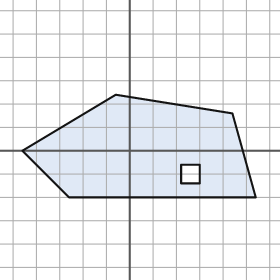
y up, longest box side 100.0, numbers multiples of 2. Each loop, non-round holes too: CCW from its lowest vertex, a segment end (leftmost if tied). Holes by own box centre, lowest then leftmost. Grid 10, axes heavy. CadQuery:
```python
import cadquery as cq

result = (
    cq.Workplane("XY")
    .moveTo(-26.0, -20.0)
    .lineTo(54.0, -20.0)
    .lineTo(44.0, 16.0)
    .lineTo(-6.0, 24.0)
    .lineTo(-46.0, 0.0)
    .close()
    .moveTo(22.0, -14.0)
    .lineTo(30.0, -14.0)
    .lineTo(30.0, -6.0)
    .lineTo(22.0, -6.0)
    .close()
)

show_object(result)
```